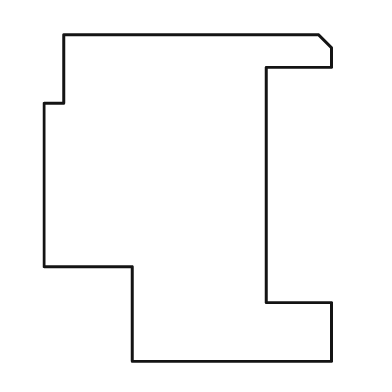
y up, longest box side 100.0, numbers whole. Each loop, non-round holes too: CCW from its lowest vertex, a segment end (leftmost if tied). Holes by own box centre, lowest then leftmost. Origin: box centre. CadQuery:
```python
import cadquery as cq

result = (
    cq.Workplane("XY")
    .moveTo(-17.0, -50.0)
    .lineTo(44.0, -50.0)
    .lineTo(44.0, -32.0)
    .lineTo(24.0, -32.0)
    .lineTo(24.0, 40.0)
    .lineTo(44.0, 40.0)
    .lineTo(44.0, 46.0)
    .lineTo(40.0, 50.0)
    .lineTo(-38.0, 50.0)
    .lineTo(-38.0, 29.0)
    .lineTo(-44.0, 29.0)
    .lineTo(-44.0, -21.0)
    .lineTo(-17.0, -21.0)
    .close()
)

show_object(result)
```